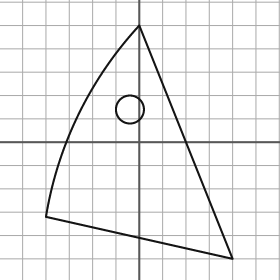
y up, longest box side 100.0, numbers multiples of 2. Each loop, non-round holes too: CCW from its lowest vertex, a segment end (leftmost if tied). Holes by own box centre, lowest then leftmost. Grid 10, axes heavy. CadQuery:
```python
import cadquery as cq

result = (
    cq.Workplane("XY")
    .moveTo(40.0, -50.0)
    .lineTo(0.0, 50.0)
    .threePointArc((-26.0, 12.0), (-40.0, -32.0))
    .close()
    .moveTo(-4.0, 14.0)
    .circle(6.0)
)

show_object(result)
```